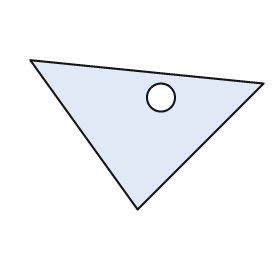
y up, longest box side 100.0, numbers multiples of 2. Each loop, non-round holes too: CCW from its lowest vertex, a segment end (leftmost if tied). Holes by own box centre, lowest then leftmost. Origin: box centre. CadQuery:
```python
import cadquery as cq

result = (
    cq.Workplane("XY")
    .moveTo(-4.0, -32.0)
    .lineTo(50.0, 22.0)
    .lineTo(-50.0, 32.0)
    .close()
    .moveTo(6.0, 16.0)
    .circle(6.0)
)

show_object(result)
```